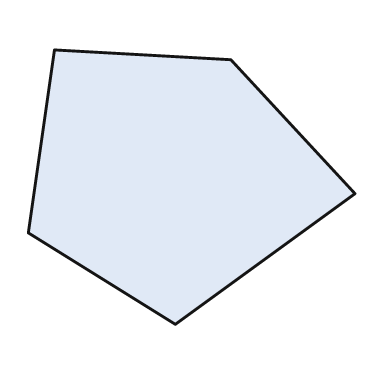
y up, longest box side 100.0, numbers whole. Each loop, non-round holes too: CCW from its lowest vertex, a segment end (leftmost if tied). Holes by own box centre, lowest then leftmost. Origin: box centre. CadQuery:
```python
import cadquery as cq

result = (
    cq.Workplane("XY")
    .moveTo(-5.0, -42.0)
    .lineTo(50.0, -2.0)
    .lineTo(12.0, 39.0)
    .lineTo(-42.0, 42.0)
    .lineTo(-50.0, -14.0)
    .close()
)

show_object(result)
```